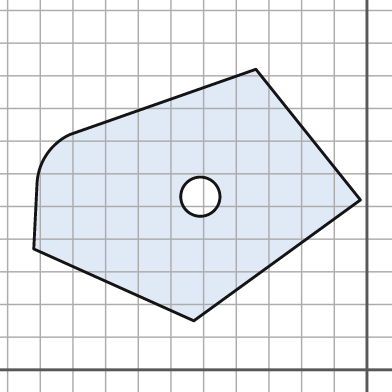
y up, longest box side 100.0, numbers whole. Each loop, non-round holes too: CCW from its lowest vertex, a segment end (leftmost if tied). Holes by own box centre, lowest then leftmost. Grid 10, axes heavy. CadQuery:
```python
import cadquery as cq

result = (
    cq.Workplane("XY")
    .moveTo(-53.0, 15.0)
    .lineTo(-2.0, 52.0)
    .lineTo(-34.0, 92.0)
    .lineTo(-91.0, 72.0)
    .threePointArc((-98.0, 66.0), (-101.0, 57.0))
    .lineTo(-102.0, 37.0)
    .close()
    .moveTo(-51.0, 53.0)
    .circle(6.0)
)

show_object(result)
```